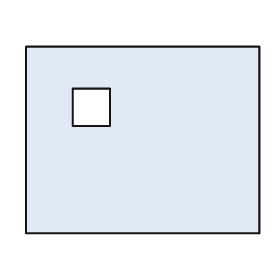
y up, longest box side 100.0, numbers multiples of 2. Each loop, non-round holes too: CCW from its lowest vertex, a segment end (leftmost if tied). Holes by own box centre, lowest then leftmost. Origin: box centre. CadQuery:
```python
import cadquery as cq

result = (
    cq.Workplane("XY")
    .moveTo(-50.0, -40.0)
    .lineTo(50.0, -40.0)
    .lineTo(50.0, 40.0)
    .lineTo(-50.0, 40.0)
    .close()
    .moveTo(-30.0, 6.0)
    .lineTo(-14.0, 6.0)
    .lineTo(-14.0, 22.0)
    .lineTo(-30.0, 22.0)
    .close()
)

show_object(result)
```